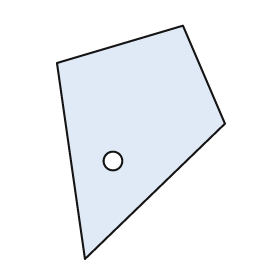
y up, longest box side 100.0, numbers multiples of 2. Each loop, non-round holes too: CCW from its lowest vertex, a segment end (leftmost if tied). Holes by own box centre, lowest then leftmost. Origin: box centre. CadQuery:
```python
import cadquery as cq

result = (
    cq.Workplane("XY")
    .moveTo(-24.0, -50.0)
    .lineTo(36.0, 8.0)
    .lineTo(18.0, 50.0)
    .lineTo(-36.0, 34.0)
    .close()
    .moveTo(-12.0, -8.0)
    .circle(4.0)
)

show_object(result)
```